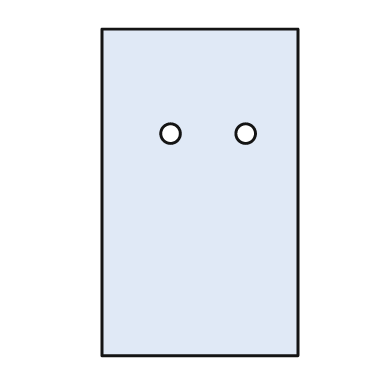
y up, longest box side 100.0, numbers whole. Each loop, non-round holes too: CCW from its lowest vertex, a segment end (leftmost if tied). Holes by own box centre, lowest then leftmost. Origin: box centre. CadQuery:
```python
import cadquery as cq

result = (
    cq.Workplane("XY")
    .moveTo(-30.0, -50.0)
    .lineTo(30.0, -50.0)
    .lineTo(30.0, 50.0)
    .lineTo(-30.0, 50.0)
    .close()
    .moveTo(-9.0, 18.0)
    .circle(3.0)
    .moveTo(14.0, 18.0)
    .circle(3.0)
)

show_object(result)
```